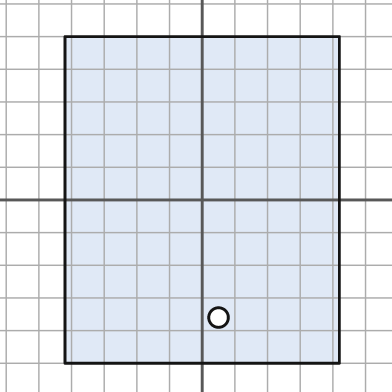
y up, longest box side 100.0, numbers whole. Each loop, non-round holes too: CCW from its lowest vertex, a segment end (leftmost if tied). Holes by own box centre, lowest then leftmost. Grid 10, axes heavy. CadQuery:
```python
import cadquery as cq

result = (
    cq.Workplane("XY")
    .moveTo(-42.0, -50.0)
    .lineTo(42.0, -50.0)
    .lineTo(42.0, 50.0)
    .lineTo(-42.0, 50.0)
    .close()
    .moveTo(5.0, -36.0)
    .circle(3.0)
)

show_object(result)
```